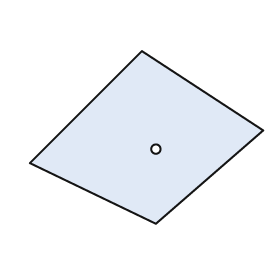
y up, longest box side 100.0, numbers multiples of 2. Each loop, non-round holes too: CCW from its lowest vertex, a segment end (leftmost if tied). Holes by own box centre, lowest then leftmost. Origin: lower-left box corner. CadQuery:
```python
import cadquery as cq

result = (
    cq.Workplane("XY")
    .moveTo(54.0, 0.0)
    .lineTo(100.0, 40.0)
    .lineTo(48.0, 74.0)
    .lineTo(0.0, 26.0)
    .close()
    .moveTo(54.0, 32.0)
    .circle(2.0)
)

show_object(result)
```